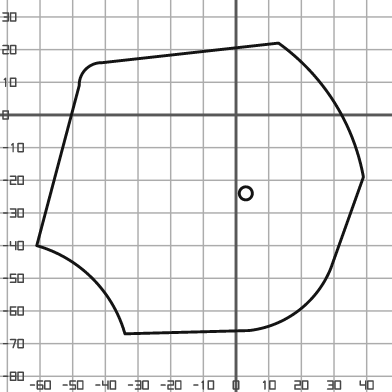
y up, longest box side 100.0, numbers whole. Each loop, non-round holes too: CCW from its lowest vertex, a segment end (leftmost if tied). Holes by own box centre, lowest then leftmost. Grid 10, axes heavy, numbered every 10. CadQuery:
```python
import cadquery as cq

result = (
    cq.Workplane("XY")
    .moveTo(-34.0, -67.0)
    .lineTo(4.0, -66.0)
    .threePointArc((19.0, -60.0), (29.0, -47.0))
    .lineTo(39.0, -19.0)
    .threePointArc((30.0, 4.0), (13.0, 22.0))
    .lineTo(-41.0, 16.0)
    .threePointArc((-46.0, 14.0), (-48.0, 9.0))
    .lineTo(-61.0, -40.0)
    .threePointArc((-44.0, -50.0), (-34.0, -67.0))
    .close()
    .moveTo(3.0, -24.0)
    .circle(2.0)
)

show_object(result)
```